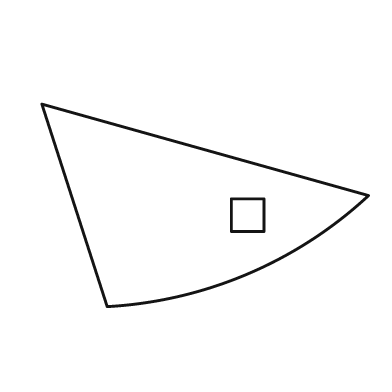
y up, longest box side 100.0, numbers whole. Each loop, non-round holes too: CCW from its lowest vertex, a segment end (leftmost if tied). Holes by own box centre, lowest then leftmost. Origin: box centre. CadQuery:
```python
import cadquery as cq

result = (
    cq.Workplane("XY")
    .moveTo(-30.0, -31.0)
    .threePointArc((13.0, -21.0), (50.0, 3.0))
    .lineTo(-50.0, 31.0)
    .close()
    .moveTo(8.0, -8.0)
    .lineTo(18.0, -8.0)
    .lineTo(18.0, 2.0)
    .lineTo(8.0, 2.0)
    .close()
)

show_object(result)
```